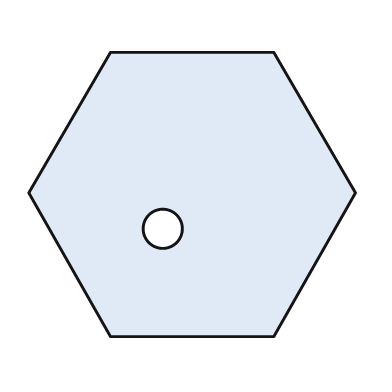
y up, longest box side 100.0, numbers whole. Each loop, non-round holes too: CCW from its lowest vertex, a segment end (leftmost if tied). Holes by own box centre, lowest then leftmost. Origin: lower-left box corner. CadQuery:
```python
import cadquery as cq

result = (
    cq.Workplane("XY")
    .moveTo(25.0, 0.0)
    .lineTo(75.0, 0.0)
    .lineTo(100.0, 44.0)
    .lineTo(75.0, 87.0)
    .lineTo(25.0, 87.0)
    .lineTo(0.0, 44.0)
    .close()
    .moveTo(41.0, 33.0)
    .circle(6.0)
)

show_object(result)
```